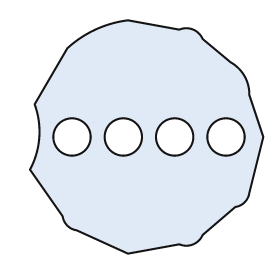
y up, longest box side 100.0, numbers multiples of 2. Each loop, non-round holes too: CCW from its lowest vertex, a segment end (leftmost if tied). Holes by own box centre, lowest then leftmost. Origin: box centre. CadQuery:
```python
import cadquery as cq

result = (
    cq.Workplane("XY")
    .moveTo(-8.0, -50.0)
    .lineTo(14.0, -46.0)
    .threePointArc((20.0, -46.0), (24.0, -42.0))
    .lineTo(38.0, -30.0)
    .threePointArc((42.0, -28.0), (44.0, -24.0))
    .lineTo(50.0, 0.0)
    .lineTo(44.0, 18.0)
    .threePointArc((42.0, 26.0), (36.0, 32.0))
    .lineTo(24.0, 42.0)
    .threePointArc((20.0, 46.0), (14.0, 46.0))
    .lineTo(-8.0, 50.0)
    .threePointArc((-22.0, 46.0), (-34.0, 38.0))
    .lineTo(-48.0, 14.0)
    .threePointArc((-46.0, 0.0), (-50.0, -14.0))
    .lineTo(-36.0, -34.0)
    .threePointArc((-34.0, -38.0), (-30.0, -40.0))
    .close()
    .moveTo(-32.0, 0.0)
    .circle(8.0)
    .moveTo(-10.0, 0.0)
    .circle(8.0)
    .moveTo(12.0, 0.0)
    .circle(8.0)
    .moveTo(34.0, 0.0)
    .circle(8.0)
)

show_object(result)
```